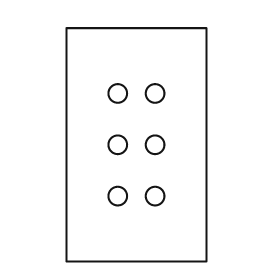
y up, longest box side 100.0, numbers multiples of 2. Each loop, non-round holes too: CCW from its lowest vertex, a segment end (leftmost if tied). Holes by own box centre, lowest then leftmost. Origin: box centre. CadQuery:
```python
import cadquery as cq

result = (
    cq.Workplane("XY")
    .moveTo(-30.0, -50.0)
    .lineTo(30.0, -50.0)
    .lineTo(30.0, 50.0)
    .lineTo(-30.0, 50.0)
    .close()
    .moveTo(-8.0, -22.0)
    .circle(4.0)
    .moveTo(8.0, -22.0)
    .circle(4.0)
    .moveTo(-8.0, 0.0)
    .circle(4.0)
    .moveTo(8.0, 0.0)
    .circle(4.0)
    .moveTo(-8.0, 22.0)
    .circle(4.0)
    .moveTo(8.0, 22.0)
    .circle(4.0)
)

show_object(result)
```